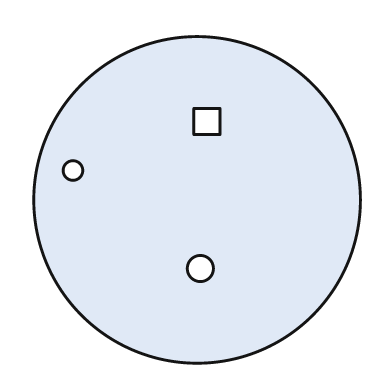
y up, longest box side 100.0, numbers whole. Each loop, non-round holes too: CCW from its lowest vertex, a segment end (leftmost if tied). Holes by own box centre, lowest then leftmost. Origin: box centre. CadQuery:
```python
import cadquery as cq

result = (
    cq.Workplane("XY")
    .moveTo(0.0, 0.0)
    .circle(50.0)
    .moveTo(1.0, -21.0)
    .circle(4.0)
    .moveTo(-38.0, 9.0)
    .circle(3.0)
    .moveTo(-1.0, 20.0)
    .lineTo(7.0, 20.0)
    .lineTo(7.0, 28.0)
    .lineTo(-1.0, 28.0)
    .close()
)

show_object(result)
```